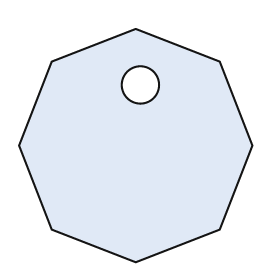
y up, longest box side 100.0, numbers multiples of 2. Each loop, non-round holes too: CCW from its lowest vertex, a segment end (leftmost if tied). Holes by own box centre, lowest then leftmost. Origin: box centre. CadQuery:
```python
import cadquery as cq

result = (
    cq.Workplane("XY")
    .moveTo(0.0, -50.0)
    .lineTo(36.0, -36.0)
    .lineTo(50.0, 0.0)
    .lineTo(36.0, 36.0)
    .lineTo(0.0, 50.0)
    .lineTo(-36.0, 36.0)
    .lineTo(-50.0, 0.0)
    .lineTo(-36.0, -36.0)
    .close()
    .moveTo(2.0, 26.0)
    .circle(8.0)
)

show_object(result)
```